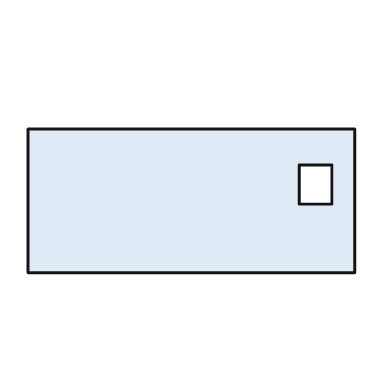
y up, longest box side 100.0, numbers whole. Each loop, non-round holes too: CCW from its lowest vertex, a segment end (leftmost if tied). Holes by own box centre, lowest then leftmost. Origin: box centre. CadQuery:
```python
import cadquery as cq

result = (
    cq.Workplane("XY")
    .moveTo(-50.0, -22.0)
    .lineTo(50.0, -22.0)
    .lineTo(50.0, 22.0)
    .lineTo(-50.0, 22.0)
    .close()
    .moveTo(33.0, -1.0)
    .lineTo(43.0, -1.0)
    .lineTo(43.0, 11.0)
    .lineTo(33.0, 11.0)
    .close()
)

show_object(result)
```